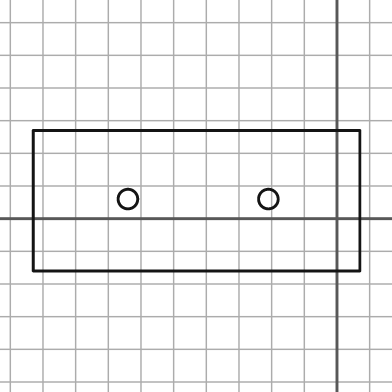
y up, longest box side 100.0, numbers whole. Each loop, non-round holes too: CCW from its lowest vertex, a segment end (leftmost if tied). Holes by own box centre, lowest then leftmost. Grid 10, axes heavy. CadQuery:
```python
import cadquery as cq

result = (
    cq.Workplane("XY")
    .moveTo(-93.0, -16.0)
    .lineTo(7.0, -16.0)
    .lineTo(7.0, 27.0)
    .lineTo(-93.0, 27.0)
    .close()
    .moveTo(-64.0, 6.0)
    .circle(3.0)
    .moveTo(-21.0, 6.0)
    .circle(3.0)
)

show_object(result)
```